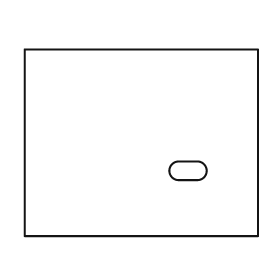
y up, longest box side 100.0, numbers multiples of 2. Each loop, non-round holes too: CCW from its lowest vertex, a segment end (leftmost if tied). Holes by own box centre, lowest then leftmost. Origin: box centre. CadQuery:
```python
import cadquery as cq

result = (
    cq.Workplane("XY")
    .moveTo(-50.0, -40.0)
    .lineTo(50.0, -40.0)
    .lineTo(50.0, 40.0)
    .lineTo(-50.0, 40.0)
    .close()
    .moveTo(16.0, -16.0)
    .lineTo(24.0, -16.0)
    .threePointArc((28.0, -12.0), (24.0, -8.0))
    .lineTo(16.0, -8.0)
    .threePointArc((12.0, -12.0), (16.0, -16.0))
    .close()
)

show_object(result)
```